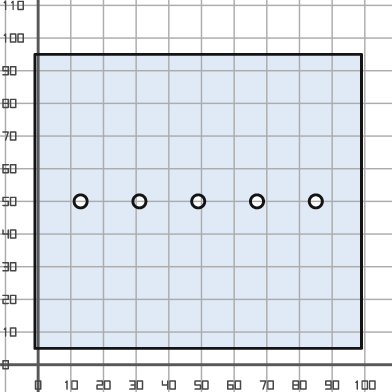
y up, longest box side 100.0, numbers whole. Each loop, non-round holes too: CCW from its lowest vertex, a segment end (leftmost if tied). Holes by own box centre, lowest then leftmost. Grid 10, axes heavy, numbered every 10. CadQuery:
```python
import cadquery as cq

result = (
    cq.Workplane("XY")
    .moveTo(-1.0, 5.0)
    .lineTo(99.0, 5.0)
    .lineTo(99.0, 95.0)
    .lineTo(-1.0, 95.0)
    .close()
    .moveTo(13.0, 50.0)
    .circle(2.0)
    .moveTo(31.0, 50.0)
    .circle(2.0)
    .moveTo(49.0, 50.0)
    .circle(2.0)
    .moveTo(67.0, 50.0)
    .circle(2.0)
    .moveTo(85.0, 50.0)
    .circle(2.0)
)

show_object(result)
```